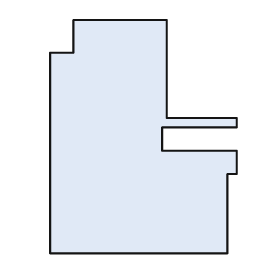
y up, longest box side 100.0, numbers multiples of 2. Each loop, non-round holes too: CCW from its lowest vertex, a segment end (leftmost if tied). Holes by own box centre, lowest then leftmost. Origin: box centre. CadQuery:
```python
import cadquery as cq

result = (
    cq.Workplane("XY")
    .moveTo(-40.0, -50.0)
    .lineTo(36.0, -50.0)
    .lineTo(36.0, -16.0)
    .lineTo(40.0, -16.0)
    .lineTo(40.0, -6.0)
    .lineTo(8.0, -6.0)
    .lineTo(8.0, 4.0)
    .lineTo(40.0, 4.0)
    .lineTo(40.0, 8.0)
    .lineTo(10.0, 8.0)
    .lineTo(10.0, 50.0)
    .lineTo(-30.0, 50.0)
    .lineTo(-30.0, 36.0)
    .lineTo(-40.0, 36.0)
    .close()
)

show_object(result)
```